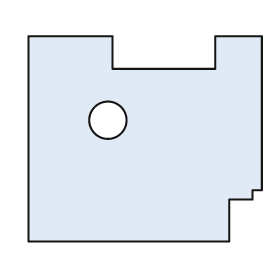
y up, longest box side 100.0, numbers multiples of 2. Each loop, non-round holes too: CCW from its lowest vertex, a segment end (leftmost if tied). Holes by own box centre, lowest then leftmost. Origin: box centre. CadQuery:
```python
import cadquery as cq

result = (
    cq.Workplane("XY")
    .moveTo(-50.0, -44.0)
    .lineTo(36.0, -44.0)
    .lineTo(36.0, -26.0)
    .lineTo(46.0, -26.0)
    .lineTo(46.0, -22.0)
    .lineTo(50.0, -22.0)
    .lineTo(50.0, 44.0)
    .lineTo(30.0, 44.0)
    .lineTo(30.0, 30.0)
    .lineTo(-14.0, 30.0)
    .lineTo(-14.0, 44.0)
    .lineTo(-50.0, 44.0)
    .close()
    .moveTo(-16.0, 8.0)
    .circle(8.0)
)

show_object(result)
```